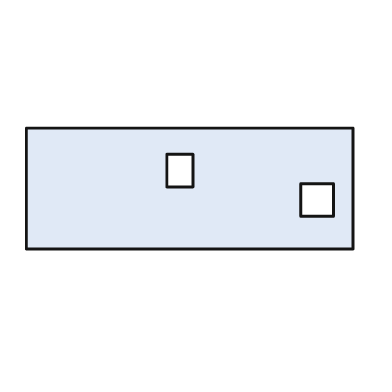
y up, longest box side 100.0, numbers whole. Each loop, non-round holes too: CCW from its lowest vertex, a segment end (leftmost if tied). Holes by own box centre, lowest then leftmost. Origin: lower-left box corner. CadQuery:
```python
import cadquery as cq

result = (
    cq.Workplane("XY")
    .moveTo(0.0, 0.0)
    .lineTo(100.0, 0.0)
    .lineTo(100.0, 37.0)
    .lineTo(0.0, 37.0)
    .close()
    .moveTo(84.0, 10.0)
    .lineTo(94.0, 10.0)
    .lineTo(94.0, 20.0)
    .lineTo(84.0, 20.0)
    .close()
    .moveTo(43.0, 19.0)
    .lineTo(51.0, 19.0)
    .lineTo(51.0, 29.0)
    .lineTo(43.0, 29.0)
    .close()
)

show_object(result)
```